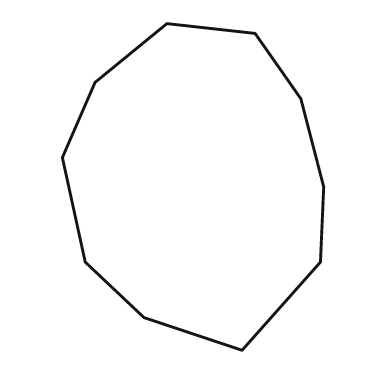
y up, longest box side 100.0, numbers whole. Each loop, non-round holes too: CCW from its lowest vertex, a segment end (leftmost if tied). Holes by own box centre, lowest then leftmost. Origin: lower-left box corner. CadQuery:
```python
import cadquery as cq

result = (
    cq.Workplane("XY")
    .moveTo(55.0, 0.0)
    .lineTo(79.0, 27.0)
    .lineTo(80.0, 50.0)
    .lineTo(73.0, 77.0)
    .lineTo(59.0, 97.0)
    .lineTo(32.0, 100.0)
    .lineTo(10.0, 82.0)
    .lineTo(0.0, 59.0)
    .lineTo(7.0, 27.0)
    .lineTo(25.0, 10.0)
    .close()
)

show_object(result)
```